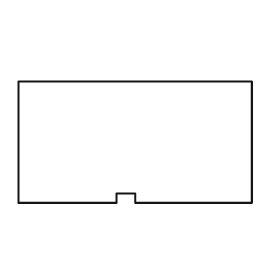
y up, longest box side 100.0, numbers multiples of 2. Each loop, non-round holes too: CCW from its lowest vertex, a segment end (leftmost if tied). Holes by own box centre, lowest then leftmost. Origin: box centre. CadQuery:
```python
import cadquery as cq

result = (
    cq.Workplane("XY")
    .moveTo(-50.0, -26.0)
    .lineTo(-8.0, -26.0)
    .lineTo(-8.0, -22.0)
    .lineTo(0.0, -22.0)
    .lineTo(0.0, -26.0)
    .lineTo(50.0, -26.0)
    .lineTo(50.0, 26.0)
    .lineTo(-50.0, 26.0)
    .close()
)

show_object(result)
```